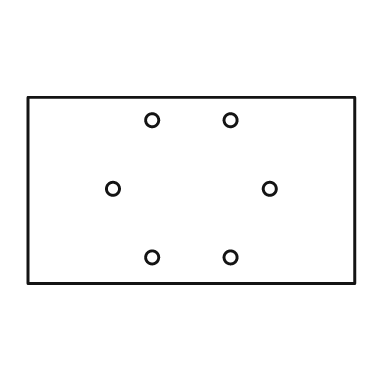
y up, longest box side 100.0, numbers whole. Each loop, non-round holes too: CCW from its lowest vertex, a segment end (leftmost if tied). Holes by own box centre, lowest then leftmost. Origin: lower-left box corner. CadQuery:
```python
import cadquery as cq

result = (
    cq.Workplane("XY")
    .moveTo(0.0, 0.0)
    .lineTo(100.0, 0.0)
    .lineTo(100.0, 57.0)
    .lineTo(0.0, 57.0)
    .close()
    .moveTo(38.0, 8.0)
    .circle(2.0)
    .moveTo(62.0, 8.0)
    .circle(2.0)
    .moveTo(26.0, 29.0)
    .circle(2.0)
    .moveTo(74.0, 29.0)
    .circle(2.0)
    .moveTo(38.0, 50.0)
    .circle(2.0)
    .moveTo(62.0, 50.0)
    .circle(2.0)
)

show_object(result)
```